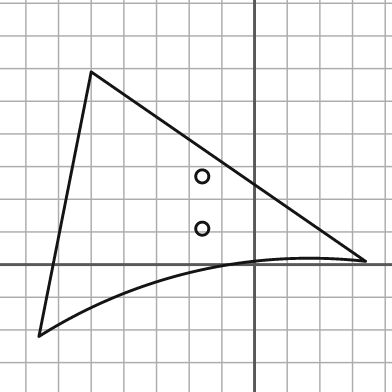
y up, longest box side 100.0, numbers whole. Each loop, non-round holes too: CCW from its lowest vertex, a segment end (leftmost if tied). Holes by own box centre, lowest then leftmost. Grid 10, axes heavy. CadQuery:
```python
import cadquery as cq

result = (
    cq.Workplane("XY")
    .moveTo(-66.0, -22.0)
    .threePointArc((-18.0, -2.0), (34.0, 1.0))
    .lineTo(-50.0, 59.0)
    .close()
    .moveTo(-16.0, 11.0)
    .circle(2.0)
    .moveTo(-16.0, 27.0)
    .circle(2.0)
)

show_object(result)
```